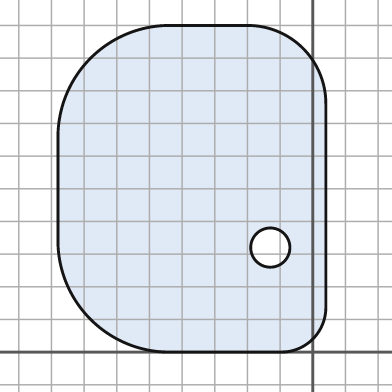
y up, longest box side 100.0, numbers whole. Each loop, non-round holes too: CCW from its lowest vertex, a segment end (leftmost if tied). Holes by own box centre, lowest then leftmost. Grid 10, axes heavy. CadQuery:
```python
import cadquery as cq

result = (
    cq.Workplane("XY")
    .moveTo(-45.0, 0.0)
    .lineTo(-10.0, 0.0)
    .threePointArc((0.0, 4.0), (4.0, 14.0))
    .lineTo(4.0, 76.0)
    .threePointArc((-3.0, 93.0), (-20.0, 100.0))
    .lineTo(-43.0, 100.0)
    .threePointArc((-68.0, 90.0), (-78.0, 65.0))
    .lineTo(-78.0, 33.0)
    .threePointArc((-68.0, 10.0), (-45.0, 0.0))
    .close()
    .moveTo(-13.0, 32.0)
    .circle(6.0)
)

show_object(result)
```